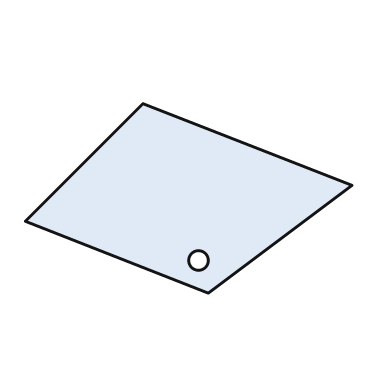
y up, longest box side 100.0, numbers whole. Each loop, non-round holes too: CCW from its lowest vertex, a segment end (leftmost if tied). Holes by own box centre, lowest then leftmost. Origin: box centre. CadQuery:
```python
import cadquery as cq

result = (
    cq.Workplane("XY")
    .moveTo(6.0, -29.0)
    .lineTo(50.0, 4.0)
    .lineTo(-14.0, 29.0)
    .lineTo(-50.0, -7.0)
    .close()
    .moveTo(3.0, -19.0)
    .circle(3.0)
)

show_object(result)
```